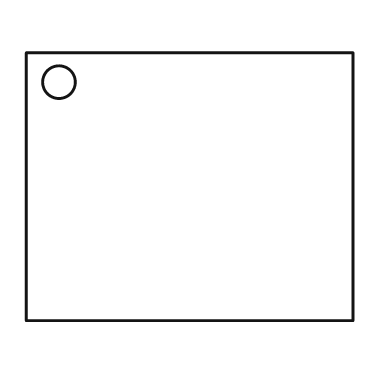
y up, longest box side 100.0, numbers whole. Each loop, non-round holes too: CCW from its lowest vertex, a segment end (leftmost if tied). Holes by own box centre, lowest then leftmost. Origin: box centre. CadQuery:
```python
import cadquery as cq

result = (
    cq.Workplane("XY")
    .moveTo(-50.0, -41.0)
    .lineTo(50.0, -41.0)
    .lineTo(50.0, 41.0)
    .lineTo(-50.0, 41.0)
    .close()
    .moveTo(-40.0, 32.0)
    .circle(5.0)
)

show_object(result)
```